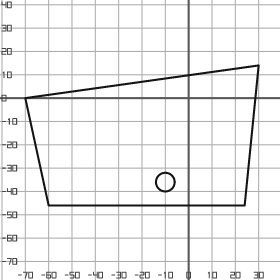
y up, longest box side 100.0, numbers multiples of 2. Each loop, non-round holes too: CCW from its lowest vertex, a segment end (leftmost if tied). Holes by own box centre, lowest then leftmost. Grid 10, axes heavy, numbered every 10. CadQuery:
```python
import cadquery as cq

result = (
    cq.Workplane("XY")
    .moveTo(-60.0, -46.0)
    .lineTo(24.0, -46.0)
    .lineTo(30.0, 14.0)
    .lineTo(-70.0, 0.0)
    .close()
    .moveTo(-10.0, -36.0)
    .circle(4.0)
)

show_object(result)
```